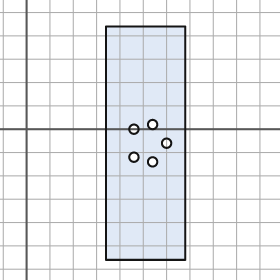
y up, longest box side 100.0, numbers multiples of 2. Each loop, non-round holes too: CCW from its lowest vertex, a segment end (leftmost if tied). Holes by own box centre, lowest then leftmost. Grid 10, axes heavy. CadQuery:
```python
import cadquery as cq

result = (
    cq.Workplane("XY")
    .moveTo(34.0, -56.0)
    .lineTo(68.0, -56.0)
    .lineTo(68.0, 44.0)
    .lineTo(34.0, 44.0)
    .close()
    .moveTo(54.0, -14.0)
    .circle(2.0)
    .moveTo(46.0, -12.0)
    .circle(2.0)
    .moveTo(60.0, -6.0)
    .circle(2.0)
    .moveTo(46.0, 0.0)
    .circle(2.0)
    .moveTo(54.0, 2.0)
    .circle(2.0)
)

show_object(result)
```